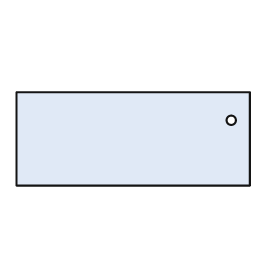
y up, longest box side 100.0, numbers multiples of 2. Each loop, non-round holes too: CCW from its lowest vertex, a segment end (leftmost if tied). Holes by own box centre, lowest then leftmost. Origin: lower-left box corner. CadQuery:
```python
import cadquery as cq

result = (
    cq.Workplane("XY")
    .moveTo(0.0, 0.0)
    .lineTo(100.0, 0.0)
    .lineTo(100.0, 40.0)
    .lineTo(0.0, 40.0)
    .close()
    .moveTo(92.0, 28.0)
    .circle(2.0)
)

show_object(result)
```